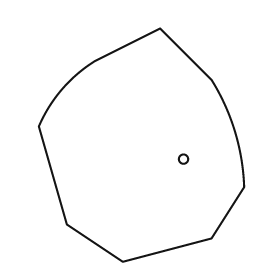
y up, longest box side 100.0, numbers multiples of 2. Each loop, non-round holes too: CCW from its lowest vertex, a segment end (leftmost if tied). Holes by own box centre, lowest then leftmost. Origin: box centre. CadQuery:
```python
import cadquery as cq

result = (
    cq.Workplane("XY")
    .moveTo(-8.0, -50.0)
    .lineTo(30.0, -40.0)
    .lineTo(44.0, -18.0)
    .threePointArc((40.0, 6.0), (30.0, 28.0))
    .lineTo(8.0, 50.0)
    .lineTo(-20.0, 36.0)
    .threePointArc((-34.0, 24.0), (-44.0, 8.0))
    .lineTo(-32.0, -34.0)
    .close()
    .moveTo(18.0, -6.0)
    .circle(2.0)
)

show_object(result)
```